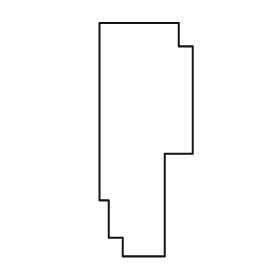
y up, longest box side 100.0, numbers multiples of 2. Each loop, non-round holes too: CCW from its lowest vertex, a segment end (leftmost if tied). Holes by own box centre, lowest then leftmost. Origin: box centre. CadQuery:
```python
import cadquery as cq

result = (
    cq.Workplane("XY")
    .moveTo(-10.0, -50.0)
    .lineTo(8.0, -50.0)
    .lineTo(8.0, -6.0)
    .lineTo(20.0, -6.0)
    .lineTo(20.0, 40.0)
    .lineTo(14.0, 40.0)
    .lineTo(14.0, 50.0)
    .lineTo(-20.0, 50.0)
    .lineTo(-20.0, -26.0)
    .lineTo(-16.0, -26.0)
    .lineTo(-16.0, -42.0)
    .lineTo(-10.0, -42.0)
    .close()
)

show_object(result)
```